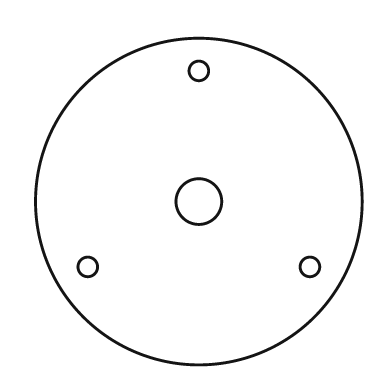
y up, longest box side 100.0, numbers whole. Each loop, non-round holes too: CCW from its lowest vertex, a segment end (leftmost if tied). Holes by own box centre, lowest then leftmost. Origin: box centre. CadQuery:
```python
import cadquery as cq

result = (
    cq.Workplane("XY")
    .moveTo(0.0, 0.0)
    .circle(50.0)
    .moveTo(-34.0, -20.0)
    .circle(3.0)
    .moveTo(34.0, -20.0)
    .circle(3.0)
    .moveTo(0.0, 0.0)
    .circle(7.0)
    .moveTo(0.0, 40.0)
    .circle(3.0)
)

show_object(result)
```